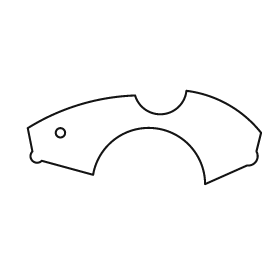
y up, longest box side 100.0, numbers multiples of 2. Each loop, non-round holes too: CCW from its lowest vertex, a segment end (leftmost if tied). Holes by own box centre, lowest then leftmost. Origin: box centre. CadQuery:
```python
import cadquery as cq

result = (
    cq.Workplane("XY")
    .moveTo(26.0, -20.0)
    .lineTo(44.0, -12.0)
    .threePointArc((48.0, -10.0), (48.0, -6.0))
    .lineTo(50.0, 2.0)
    .threePointArc((36.0, 14.0), (18.0, 20.0))
    .threePointArc((8.0, 10.0), (-4.0, 18.0))
    .threePointArc((-28.0, 14.0), (-50.0, 4.0))
    .lineTo(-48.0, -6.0)
    .threePointArc((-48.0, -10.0), (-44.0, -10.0))
    .lineTo(-22.0, -16.0)
    .threePointArc((4.0, 4.0), (26.0, -20.0))
    .close()
    .moveTo(-36.0, 2.0)
    .circle(2.0)
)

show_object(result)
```